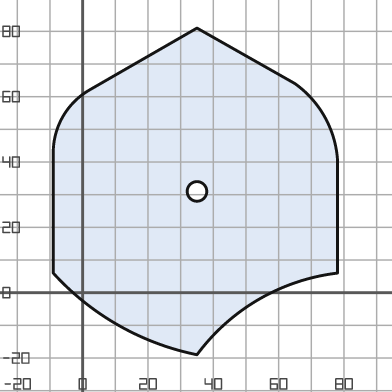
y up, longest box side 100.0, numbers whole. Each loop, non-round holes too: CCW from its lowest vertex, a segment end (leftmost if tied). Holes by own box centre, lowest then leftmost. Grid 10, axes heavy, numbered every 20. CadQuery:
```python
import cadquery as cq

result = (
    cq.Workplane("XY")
    .moveTo(35.0, -19.0)
    .threePointArc((54.0, -2.0), (78.0, 6.0))
    .lineTo(78.0, 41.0)
    .threePointArc((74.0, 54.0), (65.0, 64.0))
    .lineTo(35.0, 81.0)
    .lineTo(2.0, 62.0)
    .threePointArc((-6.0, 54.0), (-9.0, 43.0))
    .lineTo(-9.0, 6.0)
    .threePointArc((11.0, -10.0), (35.0, -19.0))
    .close()
    .moveTo(35.0, 31.0)
    .circle(3.0)
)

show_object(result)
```